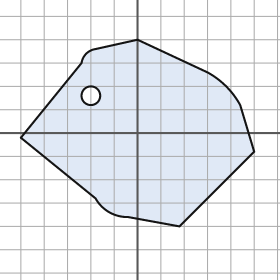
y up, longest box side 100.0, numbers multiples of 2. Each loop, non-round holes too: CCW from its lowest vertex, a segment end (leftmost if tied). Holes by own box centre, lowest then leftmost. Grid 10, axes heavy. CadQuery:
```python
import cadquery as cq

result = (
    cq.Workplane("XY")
    .moveTo(18.0, -40.0)
    .lineTo(50.0, -8.0)
    .lineTo(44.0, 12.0)
    .threePointArc((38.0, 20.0), (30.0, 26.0))
    .lineTo(0.0, 40.0)
    .lineTo(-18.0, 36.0)
    .threePointArc((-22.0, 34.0), (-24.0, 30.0))
    .lineTo(-50.0, -2.0)
    .lineTo(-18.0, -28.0)
    .threePointArc((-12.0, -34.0), (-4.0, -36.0))
    .close()
    .moveTo(-20.0, 16.0)
    .circle(4.0)
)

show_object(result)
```